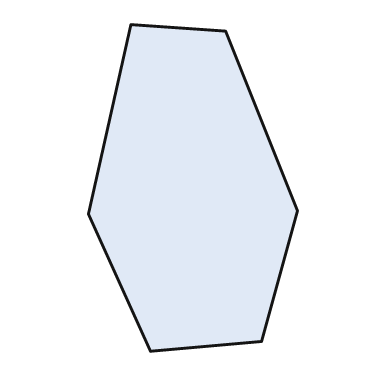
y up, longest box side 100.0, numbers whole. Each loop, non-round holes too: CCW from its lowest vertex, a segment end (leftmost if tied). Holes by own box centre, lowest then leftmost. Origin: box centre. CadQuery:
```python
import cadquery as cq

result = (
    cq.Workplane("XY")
    .moveTo(-13.0, -50.0)
    .lineTo(21.0, -47.0)
    .lineTo(32.0, -7.0)
    .lineTo(10.0, 48.0)
    .lineTo(-19.0, 50.0)
    .lineTo(-32.0, -8.0)
    .close()
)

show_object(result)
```